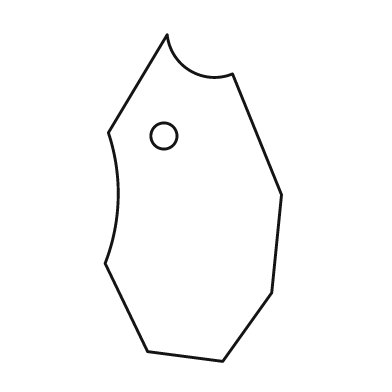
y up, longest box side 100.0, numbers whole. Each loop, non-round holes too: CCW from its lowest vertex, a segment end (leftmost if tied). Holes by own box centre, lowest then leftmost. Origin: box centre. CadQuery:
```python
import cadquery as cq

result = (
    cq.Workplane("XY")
    .moveTo(9.0, -50.0)
    .lineTo(24.0, -29.0)
    .lineTo(27.0, 1.0)
    .lineTo(12.0, 38.0)
    .threePointArc((-1.0, 39.0), (-8.0, 50.0))
    .lineTo(-26.0, 20.0)
    .threePointArc((-23.0, 0.0), (-27.0, -20.0))
    .lineTo(-14.0, -47.0)
    .close()
    .moveTo(-9.0, 19.0)
    .circle(4.0)
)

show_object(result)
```